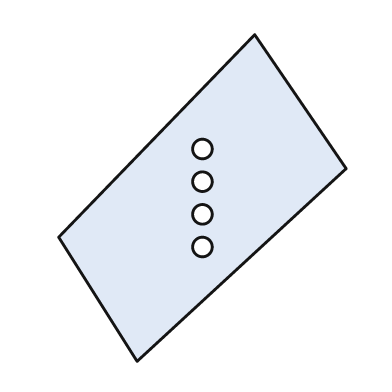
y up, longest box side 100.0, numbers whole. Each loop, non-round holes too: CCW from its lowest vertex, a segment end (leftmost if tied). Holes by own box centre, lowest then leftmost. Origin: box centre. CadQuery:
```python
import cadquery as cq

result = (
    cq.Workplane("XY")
    .moveTo(-20.0, -50.0)
    .lineTo(44.0, 9.0)
    .lineTo(16.0, 50.0)
    .lineTo(-44.0, -12.0)
    .close()
    .moveTo(0.0, -15.0)
    .circle(3.0)
    .moveTo(0.0, -5.0)
    .circle(3.0)
    .moveTo(0.0, 5.0)
    .circle(3.0)
    .moveTo(0.0, 15.0)
    .circle(3.0)
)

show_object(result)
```